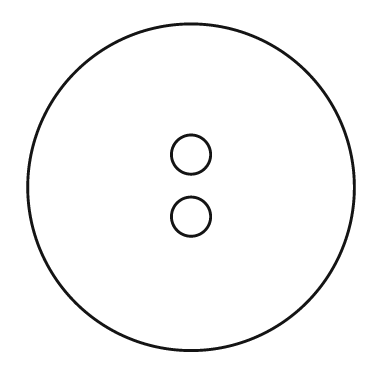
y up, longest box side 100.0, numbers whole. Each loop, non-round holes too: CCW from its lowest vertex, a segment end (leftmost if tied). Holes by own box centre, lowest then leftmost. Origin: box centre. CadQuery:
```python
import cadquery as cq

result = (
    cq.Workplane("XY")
    .moveTo(0.0, 0.0)
    .circle(50.0)
    .moveTo(0.0, -9.0)
    .circle(6.0)
    .moveTo(0.0, 10.0)
    .circle(6.0)
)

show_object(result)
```